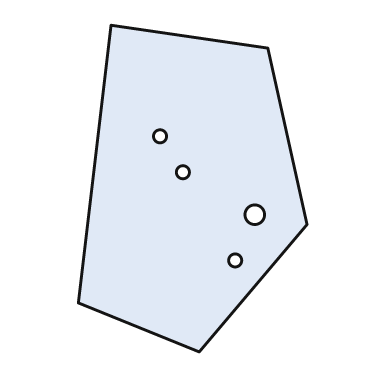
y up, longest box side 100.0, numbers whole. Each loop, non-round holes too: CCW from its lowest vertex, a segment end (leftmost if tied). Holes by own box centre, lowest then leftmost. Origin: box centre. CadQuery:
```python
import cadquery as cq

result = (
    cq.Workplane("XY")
    .moveTo(2.0, -50.0)
    .lineTo(35.0, -11.0)
    .lineTo(23.0, 43.0)
    .lineTo(-25.0, 50.0)
    .lineTo(-35.0, -35.0)
    .close()
    .moveTo(13.0, -22.0)
    .circle(2.0)
    .moveTo(19.0, -8.0)
    .circle(3.0)
    .moveTo(-3.0, 5.0)
    .circle(2.0)
    .moveTo(-10.0, 16.0)
    .circle(2.0)
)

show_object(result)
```